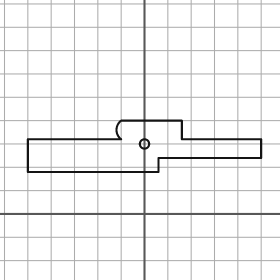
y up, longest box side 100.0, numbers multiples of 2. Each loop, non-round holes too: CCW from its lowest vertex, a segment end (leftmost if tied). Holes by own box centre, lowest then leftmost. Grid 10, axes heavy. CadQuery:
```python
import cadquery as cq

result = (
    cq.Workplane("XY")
    .moveTo(-50.0, 18.0)
    .lineTo(6.0, 18.0)
    .lineTo(6.0, 24.0)
    .lineTo(50.0, 24.0)
    .lineTo(50.0, 32.0)
    .lineTo(16.0, 32.0)
    .lineTo(16.0, 40.0)
    .lineTo(-10.0, 40.0)
    .threePointArc((-12.0, 36.0), (-10.0, 32.0))
    .lineTo(-50.0, 32.0)
    .close()
    .moveTo(0.0, 30.0)
    .circle(2.0)
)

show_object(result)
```